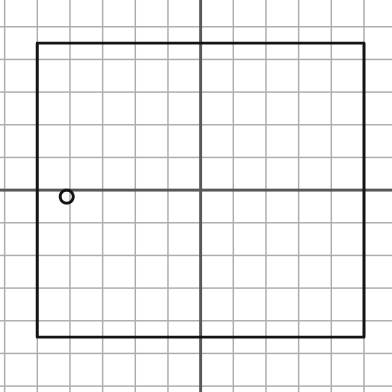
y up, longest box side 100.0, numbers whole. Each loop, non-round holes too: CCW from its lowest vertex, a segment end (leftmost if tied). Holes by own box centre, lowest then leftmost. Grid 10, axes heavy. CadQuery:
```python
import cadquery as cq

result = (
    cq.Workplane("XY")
    .moveTo(-50.0, -45.0)
    .lineTo(50.0, -45.0)
    .lineTo(50.0, 45.0)
    .lineTo(-50.0, 45.0)
    .close()
    .moveTo(-41.0, -2.0)
    .circle(2.0)
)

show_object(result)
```